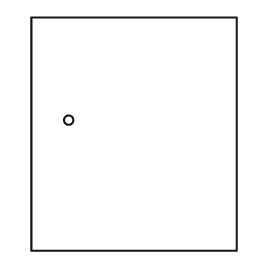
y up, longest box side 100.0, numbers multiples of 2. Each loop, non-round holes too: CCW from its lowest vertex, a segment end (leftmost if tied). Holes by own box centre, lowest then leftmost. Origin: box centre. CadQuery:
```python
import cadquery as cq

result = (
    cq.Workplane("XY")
    .moveTo(-44.0, -50.0)
    .lineTo(44.0, -50.0)
    .lineTo(44.0, 50.0)
    .lineTo(-44.0, 50.0)
    .close()
    .moveTo(-28.0, 6.0)
    .circle(2.0)
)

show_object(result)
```